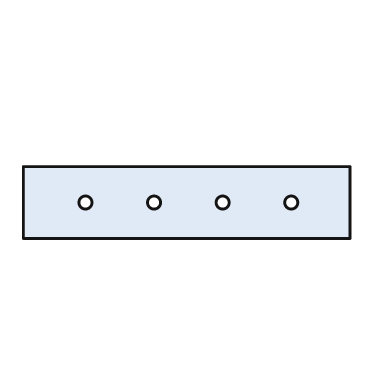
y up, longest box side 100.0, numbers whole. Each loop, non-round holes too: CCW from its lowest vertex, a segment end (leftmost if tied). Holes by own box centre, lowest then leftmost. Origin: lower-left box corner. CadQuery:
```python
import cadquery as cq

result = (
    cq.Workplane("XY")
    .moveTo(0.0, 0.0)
    .lineTo(100.0, 0.0)
    .lineTo(100.0, 22.0)
    .lineTo(0.0, 22.0)
    .close()
    .moveTo(19.0, 11.0)
    .circle(2.0)
    .moveTo(40.0, 11.0)
    .circle(2.0)
    .moveTo(61.0, 11.0)
    .circle(2.0)
    .moveTo(82.0, 11.0)
    .circle(2.0)
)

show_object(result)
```